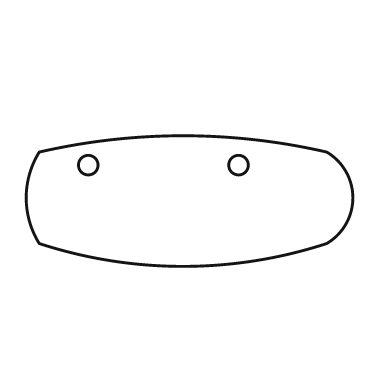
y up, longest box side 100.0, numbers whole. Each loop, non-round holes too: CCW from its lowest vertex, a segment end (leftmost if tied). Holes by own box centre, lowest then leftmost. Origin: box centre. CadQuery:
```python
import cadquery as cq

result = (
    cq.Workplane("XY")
    .moveTo(-46.0, -13.0)
    .threePointArc((-2.0, -20.0), (42.0, -13.0))
    .threePointArc((50.0, 1.0), (42.0, 15.0))
    .threePointArc((-2.0, 20.0), (-46.0, 15.0))
    .threePointArc((-50.0, 1.0), (-46.0, -13.0))
    .close()
    .moveTo(-31.0, 11.0)
    .circle(3.0)
    .moveTo(15.0, 11.0)
    .circle(3.0)
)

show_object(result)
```